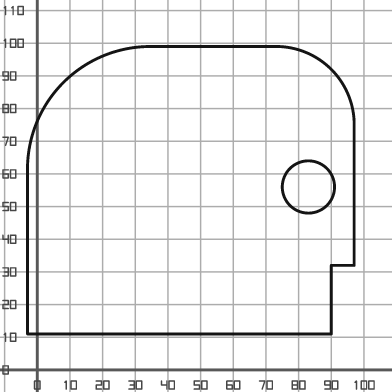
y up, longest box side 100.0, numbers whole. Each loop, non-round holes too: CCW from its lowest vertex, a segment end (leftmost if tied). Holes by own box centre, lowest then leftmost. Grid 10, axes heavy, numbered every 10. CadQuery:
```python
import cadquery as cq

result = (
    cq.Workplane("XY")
    .moveTo(-3.0, 11.0)
    .lineTo(90.0, 11.0)
    .lineTo(90.0, 32.0)
    .lineTo(97.0, 32.0)
    .lineTo(97.0, 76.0)
    .threePointArc((90.0, 92.0), (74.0, 99.0))
    .lineTo(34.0, 99.0)
    .threePointArc((8.0, 88.0), (-3.0, 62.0))
    .close()
    .moveTo(83.0, 56.0)
    .circle(8.0)
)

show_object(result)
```